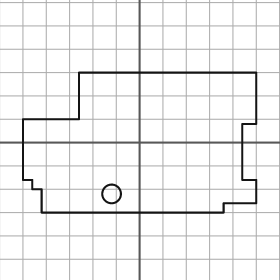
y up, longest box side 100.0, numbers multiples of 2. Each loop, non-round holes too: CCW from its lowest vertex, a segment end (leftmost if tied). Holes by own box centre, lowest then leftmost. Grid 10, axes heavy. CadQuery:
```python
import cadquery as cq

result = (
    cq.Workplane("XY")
    .moveTo(-42.0, -30.0)
    .lineTo(36.0, -30.0)
    .lineTo(36.0, -26.0)
    .lineTo(50.0, -26.0)
    .lineTo(50.0, -16.0)
    .lineTo(44.0, -16.0)
    .lineTo(44.0, 8.0)
    .lineTo(50.0, 8.0)
    .lineTo(50.0, 30.0)
    .lineTo(-26.0, 30.0)
    .lineTo(-26.0, 10.0)
    .lineTo(-50.0, 10.0)
    .lineTo(-50.0, -16.0)
    .lineTo(-46.0, -16.0)
    .lineTo(-46.0, -20.0)
    .lineTo(-42.0, -20.0)
    .close()
    .moveTo(-12.0, -22.0)
    .circle(4.0)
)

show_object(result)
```